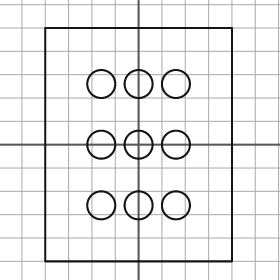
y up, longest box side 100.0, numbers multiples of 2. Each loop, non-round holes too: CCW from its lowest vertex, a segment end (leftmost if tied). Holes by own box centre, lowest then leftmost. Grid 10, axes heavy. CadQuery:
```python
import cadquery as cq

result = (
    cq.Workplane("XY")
    .moveTo(-40.0, -50.0)
    .lineTo(40.0, -50.0)
    .lineTo(40.0, 50.0)
    .lineTo(-40.0, 50.0)
    .close()
    .moveTo(-16.0, -26.0)
    .circle(6.0)
    .moveTo(0.0, -26.0)
    .circle(6.0)
    .moveTo(16.0, -26.0)
    .circle(6.0)
    .moveTo(-16.0, 0.0)
    .circle(6.0)
    .moveTo(0.0, 0.0)
    .circle(6.0)
    .moveTo(16.0, 0.0)
    .circle(6.0)
    .moveTo(-16.0, 26.0)
    .circle(6.0)
    .moveTo(0.0, 26.0)
    .circle(6.0)
    .moveTo(16.0, 26.0)
    .circle(6.0)
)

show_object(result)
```